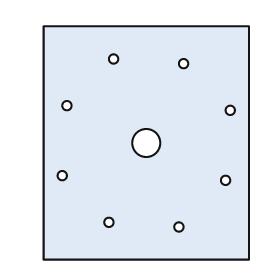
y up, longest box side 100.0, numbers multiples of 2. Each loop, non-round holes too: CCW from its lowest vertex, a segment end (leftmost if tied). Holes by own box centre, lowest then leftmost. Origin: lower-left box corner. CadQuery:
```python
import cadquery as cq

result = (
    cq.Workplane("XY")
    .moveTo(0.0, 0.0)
    .lineTo(88.0, 0.0)
    .lineTo(88.0, 100.0)
    .lineTo(0.0, 100.0)
    .close()
    .moveTo(58.0, 14.0)
    .circle(2.0)
    .moveTo(28.0, 16.0)
    .circle(2.0)
    .moveTo(78.0, 34.0)
    .circle(2.0)
    .moveTo(8.0, 36.0)
    .circle(2.0)
    .moveTo(44.0, 50.0)
    .circle(6.0)
    .moveTo(80.0, 64.0)
    .circle(2.0)
    .moveTo(10.0, 66.0)
    .circle(2.0)
    .moveTo(60.0, 84.0)
    .circle(2.0)
    .moveTo(30.0, 86.0)
    .circle(2.0)
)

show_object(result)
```